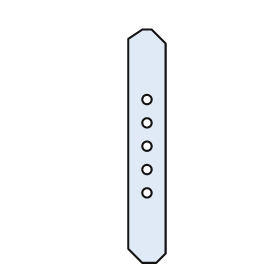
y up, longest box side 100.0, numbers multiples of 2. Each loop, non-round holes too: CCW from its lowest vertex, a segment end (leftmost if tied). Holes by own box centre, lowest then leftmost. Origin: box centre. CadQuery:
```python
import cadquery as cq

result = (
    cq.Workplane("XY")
    .moveTo(-2.0, -50.0)
    .lineTo(4.0, -50.0)
    .lineTo(8.0, -46.0)
    .lineTo(8.0, 44.0)
    .lineTo(2.0, 50.0)
    .lineTo(-2.0, 50.0)
    .lineTo(-8.0, 46.0)
    .lineTo(-8.0, -44.0)
    .close()
    .moveTo(0.0, -20.0)
    .circle(2.0)
    .moveTo(0.0, -10.0)
    .circle(2.0)
    .moveTo(0.0, 0.0)
    .circle(2.0)
    .moveTo(0.0, 10.0)
    .circle(2.0)
    .moveTo(0.0, 20.0)
    .circle(2.0)
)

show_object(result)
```